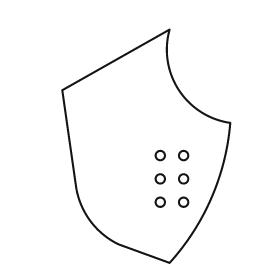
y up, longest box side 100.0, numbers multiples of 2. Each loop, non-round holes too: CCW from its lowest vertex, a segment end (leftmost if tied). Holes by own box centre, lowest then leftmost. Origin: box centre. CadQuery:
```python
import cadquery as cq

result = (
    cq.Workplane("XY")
    .moveTo(10.0, -50.0)
    .threePointArc((28.0, -22.0), (36.0, 10.0))
    .threePointArc((14.0, 24.0), (10.0, 50.0))
    .lineTo(-36.0, 24.0)
    .lineTo(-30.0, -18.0)
    .threePointArc((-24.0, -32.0), (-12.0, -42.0))
    .close()
    .moveTo(6.0, -24.0)
    .circle(2.0)
    .moveTo(16.0, -24.0)
    .circle(2.0)
    .moveTo(6.0, -14.0)
    .circle(2.0)
    .moveTo(16.0, -14.0)
    .circle(2.0)
    .moveTo(6.0, -4.0)
    .circle(2.0)
    .moveTo(16.0, -4.0)
    .circle(2.0)
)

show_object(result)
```